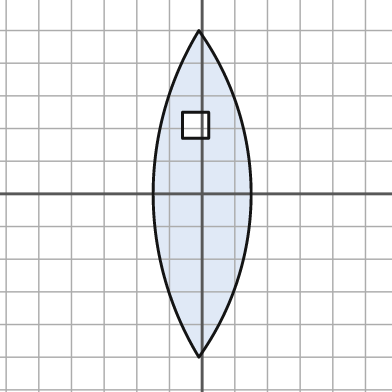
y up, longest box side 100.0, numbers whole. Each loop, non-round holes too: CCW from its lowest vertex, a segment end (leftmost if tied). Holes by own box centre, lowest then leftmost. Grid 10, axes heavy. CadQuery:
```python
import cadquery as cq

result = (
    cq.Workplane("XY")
    .moveTo(-1.0, -50.0)
    .threePointArc((15.0, 0.0), (-1.0, 50.0))
    .threePointArc((-15.0, 0.0), (-1.0, -50.0))
    .close()
    .moveTo(-6.0, 17.0)
    .lineTo(2.0, 17.0)
    .lineTo(2.0, 25.0)
    .lineTo(-6.0, 25.0)
    .close()
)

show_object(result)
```